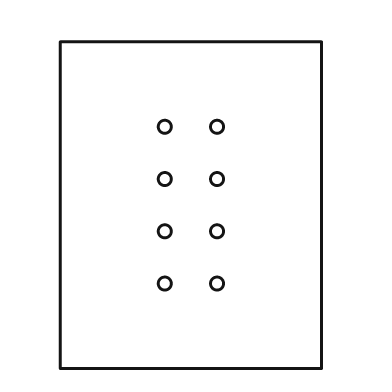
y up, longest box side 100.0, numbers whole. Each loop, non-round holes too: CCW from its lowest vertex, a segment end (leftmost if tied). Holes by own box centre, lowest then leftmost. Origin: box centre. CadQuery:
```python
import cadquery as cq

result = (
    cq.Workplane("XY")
    .moveTo(-40.0, -50.0)
    .lineTo(40.0, -50.0)
    .lineTo(40.0, 50.0)
    .lineTo(-40.0, 50.0)
    .close()
    .moveTo(-8.0, -24.0)
    .circle(2.0)
    .moveTo(8.0, -24.0)
    .circle(2.0)
    .moveTo(-8.0, -8.0)
    .circle(2.0)
    .moveTo(8.0, -8.0)
    .circle(2.0)
    .moveTo(-8.0, 8.0)
    .circle(2.0)
    .moveTo(8.0, 8.0)
    .circle(2.0)
    .moveTo(-8.0, 24.0)
    .circle(2.0)
    .moveTo(8.0, 24.0)
    .circle(2.0)
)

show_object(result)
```